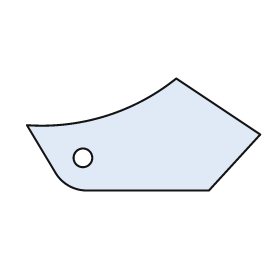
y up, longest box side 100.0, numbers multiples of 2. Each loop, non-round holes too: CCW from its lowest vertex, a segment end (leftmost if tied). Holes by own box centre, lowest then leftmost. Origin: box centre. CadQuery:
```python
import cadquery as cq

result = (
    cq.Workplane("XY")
    .moveTo(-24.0, -24.0)
    .lineTo(28.0, -24.0)
    .lineTo(50.0, 0.0)
    .lineTo(14.0, 24.0)
    .threePointArc((-16.0, 8.0), (-50.0, 4.0))
    .lineTo(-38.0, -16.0)
    .threePointArc((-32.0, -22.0), (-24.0, -24.0))
    .close()
    .moveTo(-26.0, -10.0)
    .circle(4.0)
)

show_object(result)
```